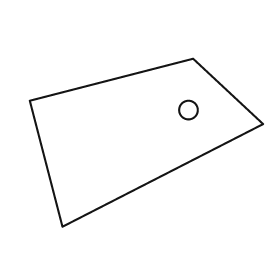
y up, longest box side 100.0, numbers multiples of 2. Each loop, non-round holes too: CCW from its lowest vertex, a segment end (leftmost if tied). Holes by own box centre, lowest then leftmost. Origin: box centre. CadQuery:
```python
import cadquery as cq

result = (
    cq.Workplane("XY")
    .moveTo(-36.0, -36.0)
    .lineTo(50.0, 8.0)
    .lineTo(20.0, 36.0)
    .lineTo(-50.0, 18.0)
    .close()
    .moveTo(18.0, 14.0)
    .circle(4.0)
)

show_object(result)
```